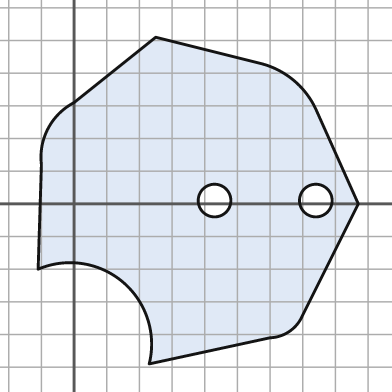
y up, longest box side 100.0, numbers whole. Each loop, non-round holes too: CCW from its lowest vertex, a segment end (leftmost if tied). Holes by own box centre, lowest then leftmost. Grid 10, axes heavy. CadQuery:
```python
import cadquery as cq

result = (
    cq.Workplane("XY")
    .moveTo(23.0, -49.0)
    .lineTo(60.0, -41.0)
    .threePointArc((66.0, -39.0), (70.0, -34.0))
    .lineTo(87.0, 0.0)
    .lineTo(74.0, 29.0)
    .threePointArc((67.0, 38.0), (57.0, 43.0))
    .lineTo(25.0, 51.0)
    .lineTo(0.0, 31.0)
    .threePointArc((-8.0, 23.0), (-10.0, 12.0))
    .lineTo(-11.0, -20.0)
    .threePointArc((15.0, -24.0), (23.0, -49.0))
    .close()
    .moveTo(43.0, 1.0)
    .circle(5.0)
    .moveTo(74.0, 1.0)
    .circle(5.0)
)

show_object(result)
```